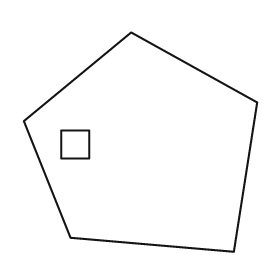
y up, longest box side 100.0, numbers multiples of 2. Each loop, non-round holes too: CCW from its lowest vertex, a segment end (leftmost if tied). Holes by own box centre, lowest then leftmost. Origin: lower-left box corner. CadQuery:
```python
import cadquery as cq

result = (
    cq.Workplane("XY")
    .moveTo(90.0, 0.0)
    .lineTo(100.0, 64.0)
    .lineTo(46.0, 94.0)
    .lineTo(0.0, 56.0)
    .lineTo(20.0, 6.0)
    .close()
    .moveTo(16.0, 40.0)
    .lineTo(28.0, 40.0)
    .lineTo(28.0, 52.0)
    .lineTo(16.0, 52.0)
    .close()
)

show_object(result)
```